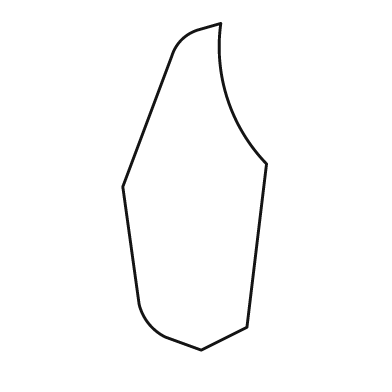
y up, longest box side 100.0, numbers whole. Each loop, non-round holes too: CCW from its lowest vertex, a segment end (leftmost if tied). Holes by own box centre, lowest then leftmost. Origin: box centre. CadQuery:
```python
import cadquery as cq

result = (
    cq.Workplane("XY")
    .moveTo(2.0, -50.0)
    .lineTo(16.0, -43.0)
    .lineTo(22.0, 7.0)
    .threePointArc((10.0, 27.0), (8.0, 50.0))
    .lineTo(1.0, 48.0)
    .threePointArc((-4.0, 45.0), (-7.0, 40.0))
    .lineTo(-22.0, 0.0)
    .lineTo(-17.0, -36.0)
    .threePointArc((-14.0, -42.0), (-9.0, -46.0))
    .close()
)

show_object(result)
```